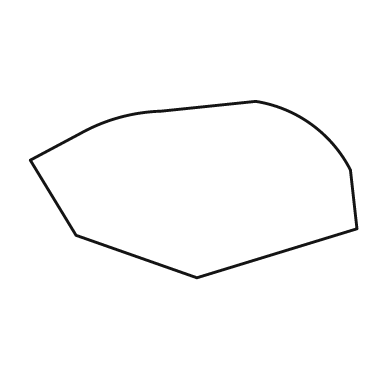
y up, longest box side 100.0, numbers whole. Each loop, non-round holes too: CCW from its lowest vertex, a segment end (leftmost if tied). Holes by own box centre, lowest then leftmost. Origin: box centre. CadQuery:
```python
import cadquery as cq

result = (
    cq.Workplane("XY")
    .moveTo(1.0, -27.0)
    .lineTo(50.0, -12.0)
    .lineTo(48.0, 6.0)
    .threePointArc((36.0, 20.0), (19.0, 27.0))
    .lineTo(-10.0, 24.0)
    .threePointArc((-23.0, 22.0), (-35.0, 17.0))
    .lineTo(-50.0, 9.0)
    .lineTo(-36.0, -14.0)
    .close()
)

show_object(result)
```